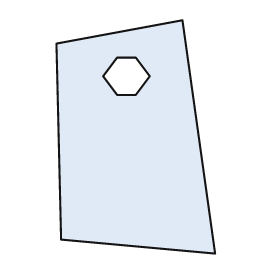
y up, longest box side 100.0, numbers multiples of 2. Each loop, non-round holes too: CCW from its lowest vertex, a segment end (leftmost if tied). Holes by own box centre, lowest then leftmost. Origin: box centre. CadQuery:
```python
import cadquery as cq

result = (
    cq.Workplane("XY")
    .moveTo(34.0, -50.0)
    .lineTo(20.0, 50.0)
    .lineTo(-34.0, 40.0)
    .lineTo(-32.0, -44.0)
    .close()
    .moveTo(-8.0, 18.0)
    .lineTo(0.0, 18.0)
    .lineTo(6.0, 26.0)
    .lineTo(0.0, 34.0)
    .lineTo(-8.0, 34.0)
    .lineTo(-14.0, 26.0)
    .close()
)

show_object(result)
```